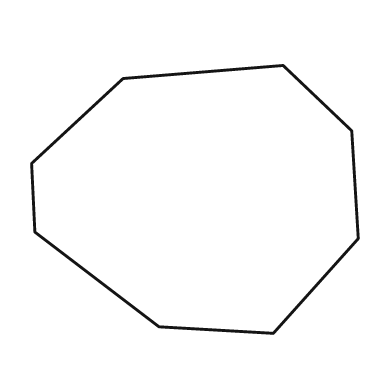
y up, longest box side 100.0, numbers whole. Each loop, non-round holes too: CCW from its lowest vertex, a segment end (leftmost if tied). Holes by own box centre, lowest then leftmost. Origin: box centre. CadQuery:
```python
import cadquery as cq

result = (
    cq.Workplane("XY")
    .moveTo(24.0, -41.0)
    .lineTo(50.0, -12.0)
    .lineTo(48.0, 21.0)
    .lineTo(27.0, 41.0)
    .lineTo(-22.0, 37.0)
    .lineTo(-50.0, 11.0)
    .lineTo(-49.0, -10.0)
    .lineTo(-11.0, -39.0)
    .close()
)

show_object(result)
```